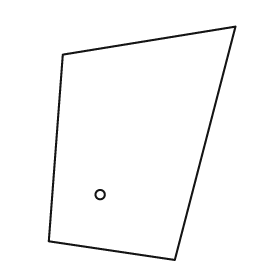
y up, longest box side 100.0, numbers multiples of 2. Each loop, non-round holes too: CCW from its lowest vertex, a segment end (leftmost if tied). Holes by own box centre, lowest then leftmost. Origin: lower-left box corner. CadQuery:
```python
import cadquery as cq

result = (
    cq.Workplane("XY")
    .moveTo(54.0, 0.0)
    .lineTo(80.0, 100.0)
    .lineTo(6.0, 88.0)
    .lineTo(0.0, 8.0)
    .close()
    .moveTo(22.0, 28.0)
    .circle(2.0)
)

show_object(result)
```